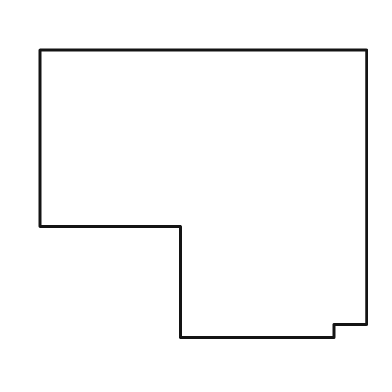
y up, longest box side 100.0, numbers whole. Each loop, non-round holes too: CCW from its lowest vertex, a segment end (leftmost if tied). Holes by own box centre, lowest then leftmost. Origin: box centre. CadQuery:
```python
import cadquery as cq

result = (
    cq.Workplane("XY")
    .moveTo(-7.0, -44.0)
    .lineTo(40.0, -44.0)
    .lineTo(40.0, -40.0)
    .lineTo(50.0, -40.0)
    .lineTo(50.0, 44.0)
    .lineTo(-50.0, 44.0)
    .lineTo(-50.0, -10.0)
    .lineTo(-7.0, -10.0)
    .close()
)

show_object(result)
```